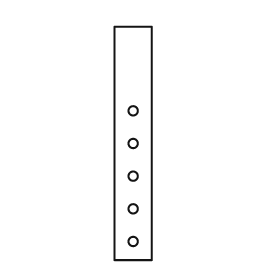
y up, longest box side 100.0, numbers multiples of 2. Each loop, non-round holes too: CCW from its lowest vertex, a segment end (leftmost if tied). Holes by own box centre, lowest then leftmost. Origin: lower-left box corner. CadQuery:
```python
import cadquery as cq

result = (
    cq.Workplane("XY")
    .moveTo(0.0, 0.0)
    .lineTo(16.0, 0.0)
    .lineTo(16.0, 100.0)
    .lineTo(0.0, 100.0)
    .close()
    .moveTo(8.0, 8.0)
    .circle(2.0)
    .moveTo(8.0, 22.0)
    .circle(2.0)
    .moveTo(8.0, 36.0)
    .circle(2.0)
    .moveTo(8.0, 50.0)
    .circle(2.0)
    .moveTo(8.0, 64.0)
    .circle(2.0)
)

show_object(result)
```